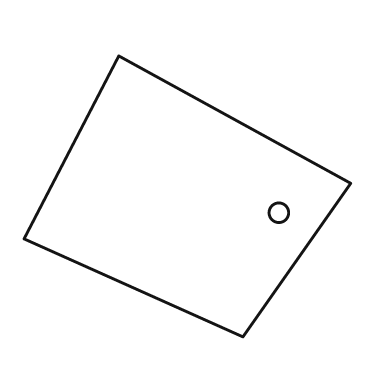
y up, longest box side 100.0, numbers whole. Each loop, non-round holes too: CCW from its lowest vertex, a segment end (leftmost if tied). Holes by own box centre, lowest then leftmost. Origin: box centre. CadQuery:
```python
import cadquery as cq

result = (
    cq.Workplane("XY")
    .moveTo(17.0, -43.0)
    .lineTo(50.0, 4.0)
    .lineTo(-21.0, 43.0)
    .lineTo(-50.0, -13.0)
    .close()
    .moveTo(28.0, -5.0)
    .circle(3.0)
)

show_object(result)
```